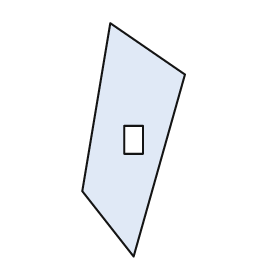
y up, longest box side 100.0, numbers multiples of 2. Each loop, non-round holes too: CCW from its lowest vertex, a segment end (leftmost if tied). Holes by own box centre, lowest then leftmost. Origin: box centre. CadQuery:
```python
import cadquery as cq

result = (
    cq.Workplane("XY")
    .moveTo(0.0, -50.0)
    .lineTo(22.0, 28.0)
    .lineTo(-10.0, 50.0)
    .lineTo(-22.0, -22.0)
    .close()
    .moveTo(-4.0, -6.0)
    .lineTo(4.0, -6.0)
    .lineTo(4.0, 6.0)
    .lineTo(-4.0, 6.0)
    .close()
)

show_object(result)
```